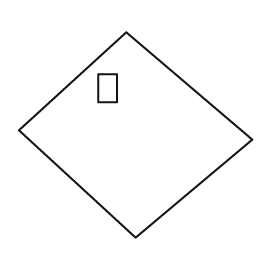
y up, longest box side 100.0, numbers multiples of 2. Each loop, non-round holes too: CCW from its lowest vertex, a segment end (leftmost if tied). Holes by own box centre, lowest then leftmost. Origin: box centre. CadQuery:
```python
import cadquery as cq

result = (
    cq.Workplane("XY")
    .moveTo(0.0, -44.0)
    .lineTo(50.0, -2.0)
    .lineTo(-4.0, 44.0)
    .lineTo(-50.0, 2.0)
    .close()
    .moveTo(-16.0, 14.0)
    .lineTo(-8.0, 14.0)
    .lineTo(-8.0, 26.0)
    .lineTo(-16.0, 26.0)
    .close()
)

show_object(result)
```